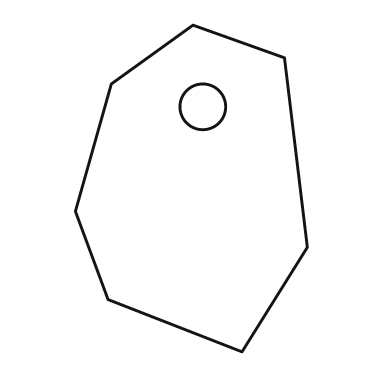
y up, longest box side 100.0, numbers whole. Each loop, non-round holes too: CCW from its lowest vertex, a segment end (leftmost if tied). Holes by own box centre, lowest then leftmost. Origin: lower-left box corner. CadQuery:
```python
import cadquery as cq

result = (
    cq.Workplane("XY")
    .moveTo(51.0, 0.0)
    .lineTo(71.0, 32.0)
    .lineTo(64.0, 90.0)
    .lineTo(36.0, 100.0)
    .lineTo(11.0, 82.0)
    .lineTo(0.0, 43.0)
    .lineTo(10.0, 16.0)
    .close()
    .moveTo(39.0, 75.0)
    .circle(7.0)
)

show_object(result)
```